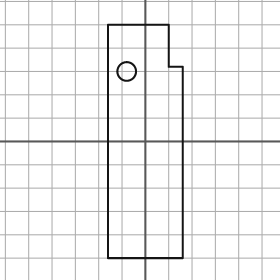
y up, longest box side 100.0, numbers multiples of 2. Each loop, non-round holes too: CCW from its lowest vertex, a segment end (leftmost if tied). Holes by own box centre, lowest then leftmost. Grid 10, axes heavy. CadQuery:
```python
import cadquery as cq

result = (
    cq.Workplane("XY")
    .moveTo(-16.0, -50.0)
    .lineTo(16.0, -50.0)
    .lineTo(16.0, 32.0)
    .lineTo(10.0, 32.0)
    .lineTo(10.0, 50.0)
    .lineTo(-16.0, 50.0)
    .close()
    .moveTo(-8.0, 30.0)
    .circle(4.0)
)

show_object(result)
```